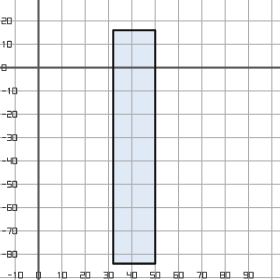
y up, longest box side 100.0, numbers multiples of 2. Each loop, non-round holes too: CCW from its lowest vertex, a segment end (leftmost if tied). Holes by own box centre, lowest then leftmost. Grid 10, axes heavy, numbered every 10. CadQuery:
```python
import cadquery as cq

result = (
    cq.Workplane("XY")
    .moveTo(32.0, -84.0)
    .lineTo(50.0, -84.0)
    .lineTo(50.0, 16.0)
    .lineTo(32.0, 16.0)
    .close()
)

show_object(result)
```